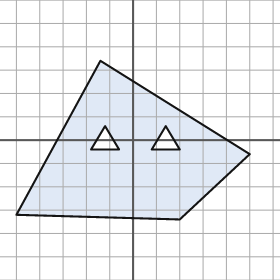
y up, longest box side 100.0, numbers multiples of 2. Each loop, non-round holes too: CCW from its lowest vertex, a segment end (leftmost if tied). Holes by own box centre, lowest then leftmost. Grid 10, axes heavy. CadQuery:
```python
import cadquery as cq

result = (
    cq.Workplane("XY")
    .moveTo(20.0, -34.0)
    .lineTo(50.0, -6.0)
    .lineTo(-14.0, 34.0)
    .lineTo(-50.0, -32.0)
    .close()
    .moveTo(-18.0, -4.0)
    .lineTo(-6.0, -4.0)
    .lineTo(-12.0, 6.0)
    .close()
    .moveTo(8.0, -4.0)
    .lineTo(20.0, -4.0)
    .lineTo(14.0, 6.0)
    .close()
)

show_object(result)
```